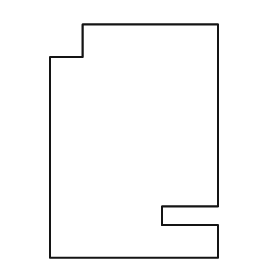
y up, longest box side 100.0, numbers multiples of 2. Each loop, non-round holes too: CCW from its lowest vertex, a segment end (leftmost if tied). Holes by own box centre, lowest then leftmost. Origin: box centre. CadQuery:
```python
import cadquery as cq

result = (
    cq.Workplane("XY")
    .moveTo(-36.0, -50.0)
    .lineTo(36.0, -50.0)
    .lineTo(36.0, -36.0)
    .lineTo(12.0, -36.0)
    .lineTo(12.0, -28.0)
    .lineTo(36.0, -28.0)
    .lineTo(36.0, 50.0)
    .lineTo(-22.0, 50.0)
    .lineTo(-22.0, 36.0)
    .lineTo(-36.0, 36.0)
    .close()
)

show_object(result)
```